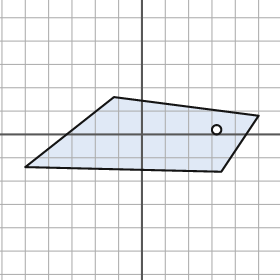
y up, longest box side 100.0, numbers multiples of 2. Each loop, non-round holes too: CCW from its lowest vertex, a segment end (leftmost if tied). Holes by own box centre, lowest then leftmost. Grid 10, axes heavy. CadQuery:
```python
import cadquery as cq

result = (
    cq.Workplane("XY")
    .moveTo(34.0, -16.0)
    .lineTo(50.0, 8.0)
    .lineTo(-12.0, 16.0)
    .lineTo(-50.0, -14.0)
    .close()
    .moveTo(32.0, 2.0)
    .circle(2.0)
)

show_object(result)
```